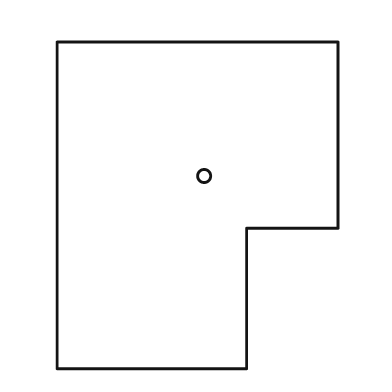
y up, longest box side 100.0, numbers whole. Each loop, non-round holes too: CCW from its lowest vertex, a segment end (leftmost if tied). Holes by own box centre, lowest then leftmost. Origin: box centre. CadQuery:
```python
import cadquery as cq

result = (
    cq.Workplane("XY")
    .moveTo(-43.0, -50.0)
    .lineTo(15.0, -50.0)
    .lineTo(15.0, -7.0)
    .lineTo(43.0, -7.0)
    .lineTo(43.0, 50.0)
    .lineTo(-43.0, 50.0)
    .close()
    .moveTo(2.0, 9.0)
    .circle(2.0)
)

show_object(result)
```